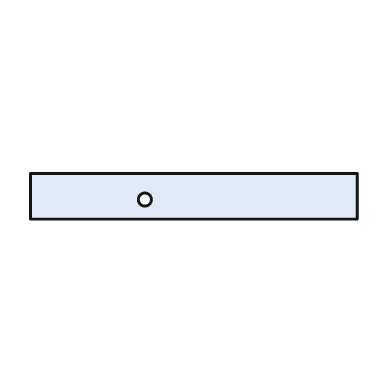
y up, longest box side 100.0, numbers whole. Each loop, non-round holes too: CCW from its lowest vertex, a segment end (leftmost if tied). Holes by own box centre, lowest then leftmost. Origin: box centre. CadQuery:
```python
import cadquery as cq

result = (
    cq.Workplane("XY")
    .moveTo(-50.0, -7.0)
    .lineTo(50.0, -7.0)
    .lineTo(50.0, 7.0)
    .lineTo(-50.0, 7.0)
    .close()
    .moveTo(-15.0, -1.0)
    .circle(2.0)
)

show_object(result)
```